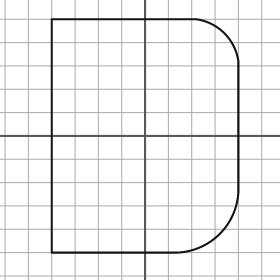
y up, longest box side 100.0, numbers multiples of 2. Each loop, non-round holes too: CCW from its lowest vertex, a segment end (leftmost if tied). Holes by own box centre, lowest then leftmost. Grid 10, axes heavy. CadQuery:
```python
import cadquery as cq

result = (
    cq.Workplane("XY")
    .moveTo(-40.0, -50.0)
    .lineTo(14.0, -50.0)
    .threePointArc((32.0, -42.0), (40.0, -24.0))
    .lineTo(40.0, 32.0)
    .threePointArc((34.0, 44.0), (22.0, 50.0))
    .lineTo(-40.0, 50.0)
    .close()
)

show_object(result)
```